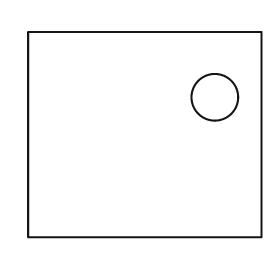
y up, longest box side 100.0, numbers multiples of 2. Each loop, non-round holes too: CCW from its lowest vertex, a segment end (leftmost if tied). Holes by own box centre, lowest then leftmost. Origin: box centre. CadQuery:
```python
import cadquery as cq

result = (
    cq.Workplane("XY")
    .moveTo(-50.0, -44.0)
    .lineTo(50.0, -44.0)
    .lineTo(50.0, 44.0)
    .lineTo(-50.0, 44.0)
    .close()
    .moveTo(30.0, 16.0)
    .circle(10.0)
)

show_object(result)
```